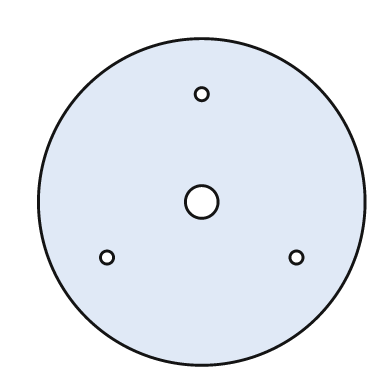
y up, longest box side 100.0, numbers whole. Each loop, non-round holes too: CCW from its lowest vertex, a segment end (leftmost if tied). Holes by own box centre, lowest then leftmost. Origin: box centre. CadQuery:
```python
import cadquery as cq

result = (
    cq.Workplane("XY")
    .moveTo(0.0, 0.0)
    .circle(50.0)
    .moveTo(-29.0, -17.0)
    .circle(2.0)
    .moveTo(29.0, -17.0)
    .circle(2.0)
    .moveTo(0.0, 0.0)
    .circle(5.0)
    .moveTo(0.0, 33.0)
    .circle(2.0)
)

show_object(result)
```